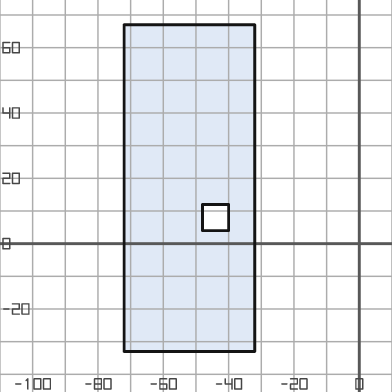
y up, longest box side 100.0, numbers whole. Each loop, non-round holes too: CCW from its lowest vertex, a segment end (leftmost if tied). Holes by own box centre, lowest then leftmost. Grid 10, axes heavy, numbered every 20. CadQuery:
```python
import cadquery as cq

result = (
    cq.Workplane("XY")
    .moveTo(-72.0, -33.0)
    .lineTo(-32.0, -33.0)
    .lineTo(-32.0, 67.0)
    .lineTo(-72.0, 67.0)
    .close()
    .moveTo(-48.0, 4.0)
    .lineTo(-40.0, 4.0)
    .lineTo(-40.0, 12.0)
    .lineTo(-48.0, 12.0)
    .close()
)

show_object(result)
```